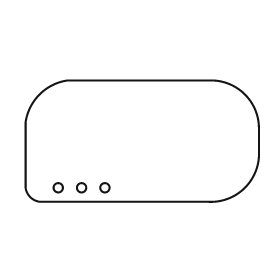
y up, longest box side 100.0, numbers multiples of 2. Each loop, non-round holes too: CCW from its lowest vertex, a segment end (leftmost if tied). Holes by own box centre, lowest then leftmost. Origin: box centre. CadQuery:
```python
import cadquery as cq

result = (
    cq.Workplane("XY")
    .moveTo(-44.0, -26.0)
    .lineTo(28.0, -26.0)
    .threePointArc((44.0, -20.0), (50.0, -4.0))
    .lineTo(50.0, 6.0)
    .threePointArc((44.0, 20.0), (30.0, 26.0))
    .lineTo(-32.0, 26.0)
    .threePointArc((-44.0, 20.0), (-50.0, 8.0))
    .lineTo(-50.0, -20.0)
    .threePointArc((-48.0, -24.0), (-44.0, -26.0))
    .close()
    .moveTo(-36.0, -20.0)
    .circle(2.0)
    .moveTo(-26.0, -20.0)
    .circle(2.0)
    .moveTo(-16.0, -20.0)
    .circle(2.0)
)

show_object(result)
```